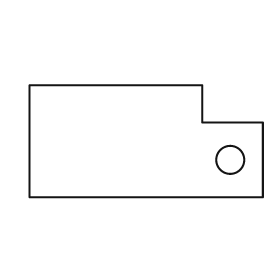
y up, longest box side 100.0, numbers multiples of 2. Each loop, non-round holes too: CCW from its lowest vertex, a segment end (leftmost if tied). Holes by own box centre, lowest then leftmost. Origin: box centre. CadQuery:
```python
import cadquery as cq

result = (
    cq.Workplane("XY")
    .moveTo(-50.0, -24.0)
    .lineTo(50.0, -24.0)
    .lineTo(50.0, 8.0)
    .lineTo(24.0, 8.0)
    .lineTo(24.0, 24.0)
    .lineTo(-50.0, 24.0)
    .close()
    .moveTo(36.0, -8.0)
    .circle(6.0)
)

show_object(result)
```